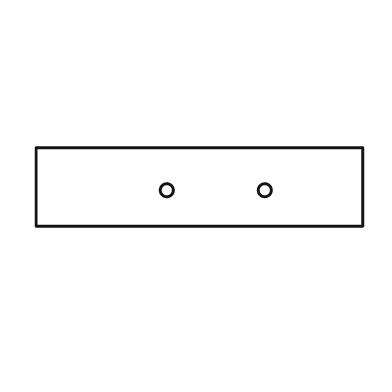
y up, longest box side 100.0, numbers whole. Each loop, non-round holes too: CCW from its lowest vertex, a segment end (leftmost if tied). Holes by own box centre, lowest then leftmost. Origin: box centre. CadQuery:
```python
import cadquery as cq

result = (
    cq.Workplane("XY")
    .moveTo(-50.0, -12.0)
    .lineTo(50.0, -12.0)
    .lineTo(50.0, 12.0)
    .lineTo(-50.0, 12.0)
    .close()
    .moveTo(-10.0, -1.0)
    .circle(2.0)
    .moveTo(20.0, -1.0)
    .circle(2.0)
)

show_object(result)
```